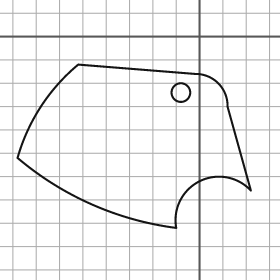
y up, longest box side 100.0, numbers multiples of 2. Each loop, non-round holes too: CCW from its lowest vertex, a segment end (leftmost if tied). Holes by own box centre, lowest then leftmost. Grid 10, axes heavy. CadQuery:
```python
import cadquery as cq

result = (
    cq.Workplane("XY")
    .moveTo(-10.0, -82.0)
    .threePointArc((0.0, -62.0), (22.0, -66.0))
    .lineTo(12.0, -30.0)
    .threePointArc((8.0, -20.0), (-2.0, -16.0))
    .lineTo(-52.0, -12.0)
    .threePointArc((-68.0, -30.0), (-78.0, -52.0))
    .threePointArc((-46.0, -72.0), (-10.0, -82.0))
    .close()
    .moveTo(-8.0, -24.0)
    .circle(4.0)
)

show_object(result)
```